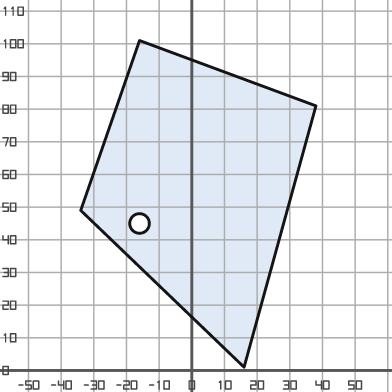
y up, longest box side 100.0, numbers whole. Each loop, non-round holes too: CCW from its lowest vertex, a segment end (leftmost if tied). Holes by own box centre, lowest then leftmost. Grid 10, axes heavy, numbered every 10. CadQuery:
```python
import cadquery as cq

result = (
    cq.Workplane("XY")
    .moveTo(16.0, 1.0)
    .lineTo(38.0, 81.0)
    .lineTo(-16.0, 101.0)
    .lineTo(-34.0, 49.0)
    .close()
    .moveTo(-16.0, 45.0)
    .circle(3.0)
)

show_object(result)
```